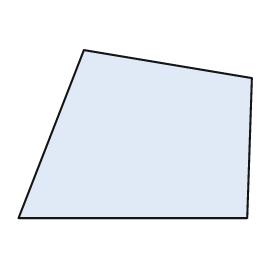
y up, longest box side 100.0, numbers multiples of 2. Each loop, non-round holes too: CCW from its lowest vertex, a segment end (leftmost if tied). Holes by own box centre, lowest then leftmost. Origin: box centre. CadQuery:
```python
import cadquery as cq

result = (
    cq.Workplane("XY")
    .moveTo(-50.0, -36.0)
    .lineTo(48.0, -36.0)
    .lineTo(50.0, 24.0)
    .lineTo(-22.0, 36.0)
    .close()
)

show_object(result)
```